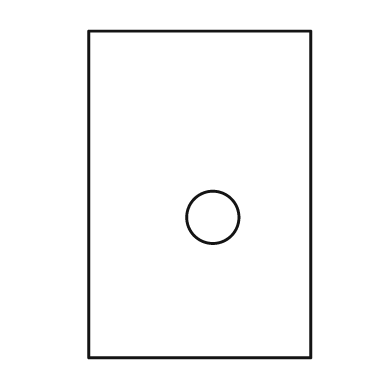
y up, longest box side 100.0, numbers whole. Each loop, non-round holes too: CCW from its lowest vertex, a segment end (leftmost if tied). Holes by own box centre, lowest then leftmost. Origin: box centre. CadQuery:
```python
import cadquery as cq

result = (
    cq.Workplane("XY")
    .moveTo(-34.0, -50.0)
    .lineTo(34.0, -50.0)
    .lineTo(34.0, 50.0)
    .lineTo(-34.0, 50.0)
    .close()
    .moveTo(4.0, -7.0)
    .circle(8.0)
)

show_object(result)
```